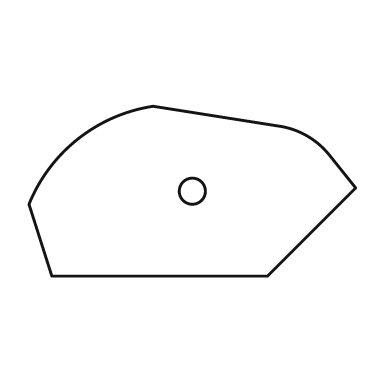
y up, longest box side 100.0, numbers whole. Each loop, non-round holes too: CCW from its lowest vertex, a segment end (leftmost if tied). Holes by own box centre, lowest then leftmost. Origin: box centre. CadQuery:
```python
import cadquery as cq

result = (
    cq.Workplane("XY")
    .moveTo(-43.0, -26.0)
    .lineTo(23.0, -26.0)
    .lineTo(50.0, 1.0)
    .lineTo(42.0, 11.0)
    .threePointArc((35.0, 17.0), (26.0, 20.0))
    .lineTo(-12.0, 26.0)
    .threePointArc((-35.0, 16.0), (-50.0, -4.0))
    .close()
    .moveTo(0.0, 0.0)
    .circle(4.0)
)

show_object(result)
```